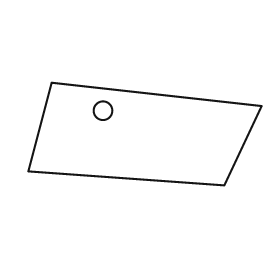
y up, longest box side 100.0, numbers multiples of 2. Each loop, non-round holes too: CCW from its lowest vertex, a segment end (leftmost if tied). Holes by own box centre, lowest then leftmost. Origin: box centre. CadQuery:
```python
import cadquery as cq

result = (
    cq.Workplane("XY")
    .moveTo(34.0, -22.0)
    .lineTo(50.0, 12.0)
    .lineTo(-40.0, 22.0)
    .lineTo(-50.0, -16.0)
    .close()
    .moveTo(-18.0, 10.0)
    .circle(4.0)
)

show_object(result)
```